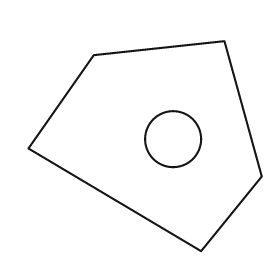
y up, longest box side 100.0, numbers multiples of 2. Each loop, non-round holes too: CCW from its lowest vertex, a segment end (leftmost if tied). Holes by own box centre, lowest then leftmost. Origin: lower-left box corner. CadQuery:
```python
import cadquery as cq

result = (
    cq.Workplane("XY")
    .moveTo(74.0, 0.0)
    .lineTo(100.0, 32.0)
    .lineTo(84.0, 90.0)
    .lineTo(28.0, 84.0)
    .lineTo(0.0, 44.0)
    .close()
    .moveTo(62.0, 48.0)
    .circle(12.0)
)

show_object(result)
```